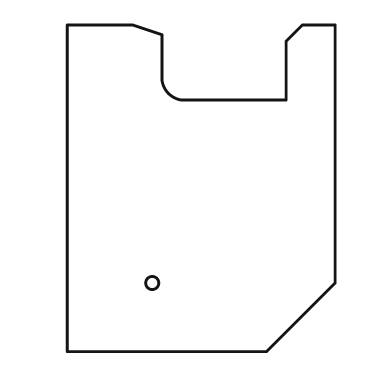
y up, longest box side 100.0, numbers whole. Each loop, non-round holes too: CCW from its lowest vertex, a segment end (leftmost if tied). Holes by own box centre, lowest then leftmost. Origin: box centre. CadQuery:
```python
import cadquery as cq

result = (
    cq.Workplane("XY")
    .moveTo(-41.0, -50.0)
    .lineTo(20.0, -50.0)
    .lineTo(41.0, -29.0)
    .lineTo(41.0, 50.0)
    .lineTo(31.0, 50.0)
    .lineTo(26.0, 45.0)
    .lineTo(26.0, 27.0)
    .lineTo(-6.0, 27.0)
    .threePointArc((-10.0, 29.0), (-12.0, 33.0))
    .lineTo(-12.0, 47.0)
    .lineTo(-21.0, 50.0)
    .lineTo(-41.0, 50.0)
    .close()
    .moveTo(-15.0, -29.0)
    .circle(2.0)
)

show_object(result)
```